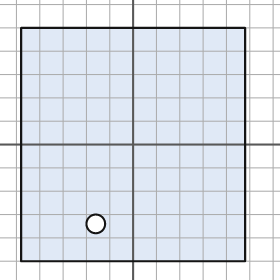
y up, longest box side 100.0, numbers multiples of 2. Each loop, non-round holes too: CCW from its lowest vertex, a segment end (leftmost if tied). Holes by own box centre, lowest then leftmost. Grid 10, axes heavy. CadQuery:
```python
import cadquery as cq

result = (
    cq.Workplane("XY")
    .moveTo(-48.0, -50.0)
    .lineTo(48.0, -50.0)
    .lineTo(48.0, 50.0)
    .lineTo(-48.0, 50.0)
    .close()
    .moveTo(-16.0, -34.0)
    .circle(4.0)
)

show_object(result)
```